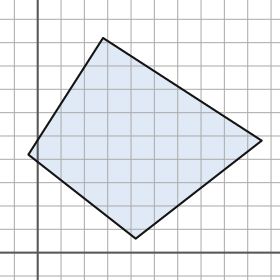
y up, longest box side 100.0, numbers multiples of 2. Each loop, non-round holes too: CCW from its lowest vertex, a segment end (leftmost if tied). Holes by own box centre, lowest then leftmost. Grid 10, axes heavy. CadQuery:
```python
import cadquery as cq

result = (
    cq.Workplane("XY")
    .moveTo(42.0, 6.0)
    .lineTo(96.0, 48.0)
    .lineTo(28.0, 92.0)
    .lineTo(-4.0, 42.0)
    .close()
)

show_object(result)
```